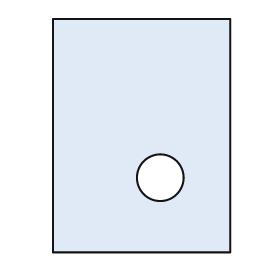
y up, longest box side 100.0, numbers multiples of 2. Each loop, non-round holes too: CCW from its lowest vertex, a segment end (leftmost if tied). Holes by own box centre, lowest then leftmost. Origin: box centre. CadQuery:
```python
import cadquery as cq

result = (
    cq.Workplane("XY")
    .moveTo(-38.0, -50.0)
    .lineTo(38.0, -50.0)
    .lineTo(38.0, 50.0)
    .lineTo(-38.0, 50.0)
    .close()
    .moveTo(8.0, -18.0)
    .circle(10.0)
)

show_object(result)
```